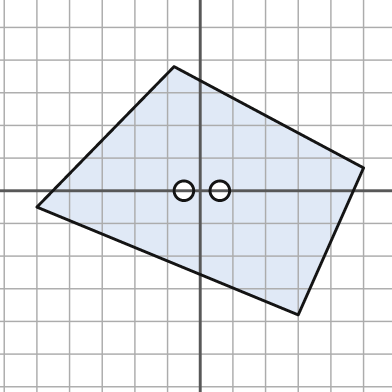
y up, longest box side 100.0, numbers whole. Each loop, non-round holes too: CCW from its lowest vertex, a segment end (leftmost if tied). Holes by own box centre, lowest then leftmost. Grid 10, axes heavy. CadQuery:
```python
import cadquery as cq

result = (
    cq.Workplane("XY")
    .moveTo(30.0, -38.0)
    .lineTo(50.0, 7.0)
    .lineTo(-8.0, 38.0)
    .lineTo(-50.0, -5.0)
    .close()
    .moveTo(-5.0, 0.0)
    .circle(3.0)
    .moveTo(6.0, 0.0)
    .circle(3.0)
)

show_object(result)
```